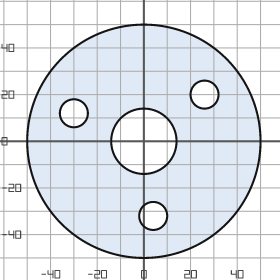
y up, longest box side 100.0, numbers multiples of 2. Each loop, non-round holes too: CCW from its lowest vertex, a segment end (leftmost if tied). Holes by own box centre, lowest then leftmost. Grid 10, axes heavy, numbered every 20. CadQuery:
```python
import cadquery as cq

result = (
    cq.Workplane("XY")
    .moveTo(0.0, 0.0)
    .circle(50.0)
    .moveTo(4.0, -32.0)
    .circle(6.0)
    .moveTo(0.0, 0.0)
    .circle(14.0)
    .moveTo(-30.0, 12.0)
    .circle(6.0)
    .moveTo(26.0, 20.0)
    .circle(6.0)
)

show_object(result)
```